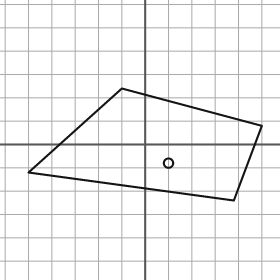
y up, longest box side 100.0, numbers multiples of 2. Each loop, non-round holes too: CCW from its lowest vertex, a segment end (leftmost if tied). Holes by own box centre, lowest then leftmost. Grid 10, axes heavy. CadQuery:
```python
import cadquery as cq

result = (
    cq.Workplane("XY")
    .moveTo(38.0, -24.0)
    .lineTo(50.0, 8.0)
    .lineTo(-10.0, 24.0)
    .lineTo(-50.0, -12.0)
    .close()
    .moveTo(10.0, -8.0)
    .circle(2.0)
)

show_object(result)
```